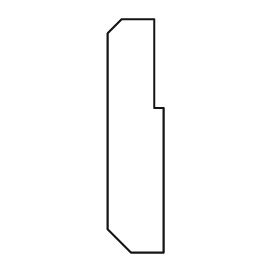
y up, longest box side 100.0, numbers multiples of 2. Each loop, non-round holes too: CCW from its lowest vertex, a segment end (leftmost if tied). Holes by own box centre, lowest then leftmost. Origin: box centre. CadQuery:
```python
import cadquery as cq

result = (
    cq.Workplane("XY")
    .moveTo(-2.0, -50.0)
    .lineTo(12.0, -50.0)
    .lineTo(12.0, 12.0)
    .lineTo(8.0, 12.0)
    .lineTo(8.0, 50.0)
    .lineTo(-6.0, 50.0)
    .lineTo(-12.0, 44.0)
    .lineTo(-12.0, -40.0)
    .close()
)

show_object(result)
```